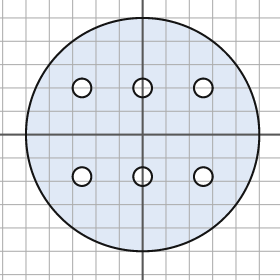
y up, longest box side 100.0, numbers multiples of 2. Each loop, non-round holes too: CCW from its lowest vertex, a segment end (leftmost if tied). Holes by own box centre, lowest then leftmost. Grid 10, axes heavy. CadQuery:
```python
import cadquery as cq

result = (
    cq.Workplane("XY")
    .moveTo(0.0, 0.0)
    .circle(50.0)
    .moveTo(-26.0, -18.0)
    .circle(4.0)
    .moveTo(0.0, -18.0)
    .circle(4.0)
    .moveTo(26.0, -18.0)
    .circle(4.0)
    .moveTo(-26.0, 20.0)
    .circle(4.0)
    .moveTo(0.0, 20.0)
    .circle(4.0)
    .moveTo(26.0, 20.0)
    .circle(4.0)
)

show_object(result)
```